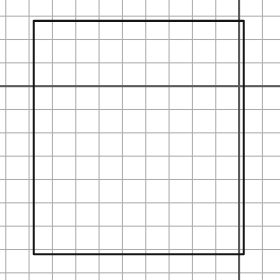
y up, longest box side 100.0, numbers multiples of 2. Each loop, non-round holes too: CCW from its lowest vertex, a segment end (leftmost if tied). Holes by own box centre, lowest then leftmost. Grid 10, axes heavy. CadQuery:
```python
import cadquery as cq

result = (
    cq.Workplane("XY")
    .moveTo(-88.0, -72.0)
    .lineTo(2.0, -72.0)
    .lineTo(2.0, 28.0)
    .lineTo(-88.0, 28.0)
    .close()
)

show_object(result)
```